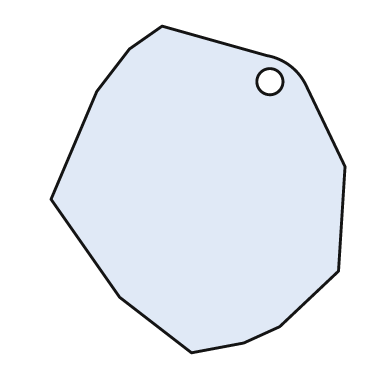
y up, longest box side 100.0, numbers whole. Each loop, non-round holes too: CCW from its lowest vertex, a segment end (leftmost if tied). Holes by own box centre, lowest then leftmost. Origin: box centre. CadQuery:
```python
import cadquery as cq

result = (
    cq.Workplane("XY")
    .moveTo(-2.0, -50.0)
    .lineTo(14.0, -47.0)
    .lineTo(25.0, -42.0)
    .lineTo(43.0, -25.0)
    .lineTo(45.0, 7.0)
    .lineTo(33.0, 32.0)
    .threePointArc((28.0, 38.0), (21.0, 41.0))
    .lineTo(-11.0, 50.0)
    .lineTo(-21.0, 43.0)
    .lineTo(-31.0, 30.0)
    .lineTo(-45.0, -3.0)
    .lineTo(-24.0, -33.0)
    .close()
    .moveTo(22.0, 33.0)
    .circle(4.0)
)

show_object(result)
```